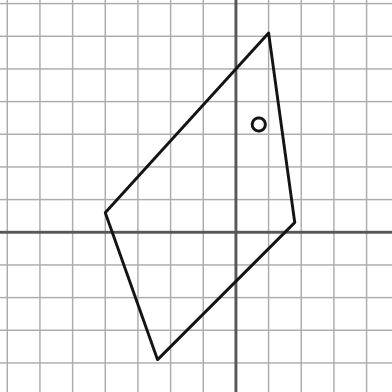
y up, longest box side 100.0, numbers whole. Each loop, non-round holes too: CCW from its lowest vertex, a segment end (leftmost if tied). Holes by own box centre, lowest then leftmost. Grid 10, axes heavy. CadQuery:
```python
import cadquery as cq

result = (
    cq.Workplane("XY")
    .moveTo(-24.0, -39.0)
    .lineTo(18.0, 3.0)
    .lineTo(10.0, 61.0)
    .lineTo(-40.0, 6.0)
    .close()
    .moveTo(7.0, 33.0)
    .circle(2.0)
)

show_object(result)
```